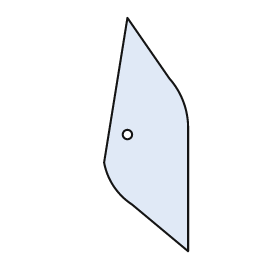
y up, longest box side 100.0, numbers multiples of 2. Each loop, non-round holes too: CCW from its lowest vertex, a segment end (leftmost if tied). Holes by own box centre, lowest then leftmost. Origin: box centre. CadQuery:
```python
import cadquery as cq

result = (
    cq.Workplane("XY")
    .moveTo(18.0, -50.0)
    .lineTo(18.0, 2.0)
    .threePointArc((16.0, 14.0), (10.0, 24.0))
    .lineTo(-8.0, 50.0)
    .lineTo(-18.0, -12.0)
    .threePointArc((-14.0, -22.0), (-6.0, -30.0))
    .close()
    .moveTo(-8.0, 0.0)
    .circle(2.0)
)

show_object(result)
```